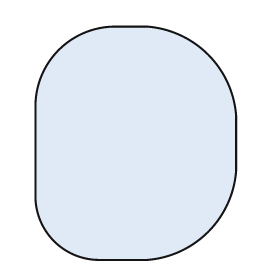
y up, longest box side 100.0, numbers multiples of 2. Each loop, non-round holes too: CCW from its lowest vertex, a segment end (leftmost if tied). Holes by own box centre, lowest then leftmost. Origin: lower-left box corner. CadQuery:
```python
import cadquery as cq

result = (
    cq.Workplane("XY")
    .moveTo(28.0, 0.0)
    .lineTo(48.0, 0.0)
    .threePointArc((74.0, 12.0), (86.0, 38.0))
    .lineTo(86.0, 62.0)
    .threePointArc((74.0, 88.0), (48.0, 100.0))
    .lineTo(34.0, 100.0)
    .threePointArc((10.0, 90.0), (0.0, 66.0))
    .lineTo(0.0, 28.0)
    .threePointArc((8.0, 8.0), (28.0, 0.0))
    .close()
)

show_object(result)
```